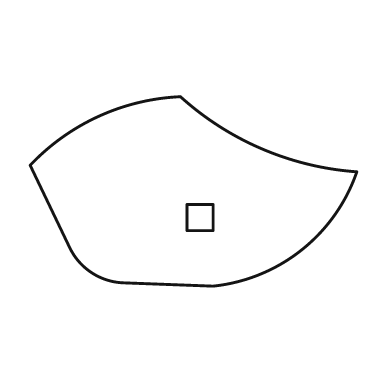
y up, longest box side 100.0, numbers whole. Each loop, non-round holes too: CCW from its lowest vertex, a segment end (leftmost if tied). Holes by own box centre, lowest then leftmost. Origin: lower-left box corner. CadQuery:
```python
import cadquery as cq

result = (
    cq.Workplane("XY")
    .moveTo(56.0, 0.0)
    .threePointArc((83.0, 11.0), (100.0, 35.0))
    .threePointArc((71.0, 42.0), (46.0, 58.0))
    .threePointArc((21.0, 52.0), (0.0, 37.0))
    .lineTo(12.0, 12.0)
    .threePointArc((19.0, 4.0), (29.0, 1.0))
    .close()
    .moveTo(48.0, 17.0)
    .lineTo(56.0, 17.0)
    .lineTo(56.0, 25.0)
    .lineTo(48.0, 25.0)
    .close()
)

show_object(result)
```